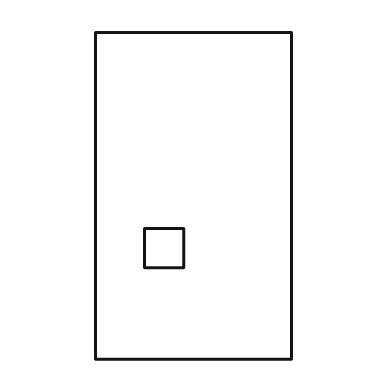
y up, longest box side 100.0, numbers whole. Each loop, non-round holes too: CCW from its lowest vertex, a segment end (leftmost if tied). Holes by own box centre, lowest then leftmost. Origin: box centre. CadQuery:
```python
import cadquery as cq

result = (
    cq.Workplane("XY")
    .moveTo(-30.0, -50.0)
    .lineTo(30.0, -50.0)
    .lineTo(30.0, 50.0)
    .lineTo(-30.0, 50.0)
    .close()
    .moveTo(-15.0, -22.0)
    .lineTo(-3.0, -22.0)
    .lineTo(-3.0, -10.0)
    .lineTo(-15.0, -10.0)
    .close()
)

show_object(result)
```